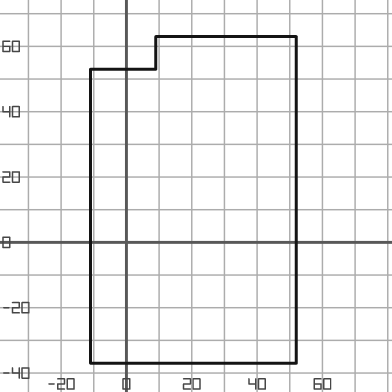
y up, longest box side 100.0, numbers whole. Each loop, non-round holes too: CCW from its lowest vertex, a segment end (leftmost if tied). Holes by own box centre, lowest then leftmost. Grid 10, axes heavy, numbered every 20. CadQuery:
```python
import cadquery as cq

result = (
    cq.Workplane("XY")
    .moveTo(-11.0, -37.0)
    .lineTo(52.0, -37.0)
    .lineTo(52.0, 63.0)
    .lineTo(9.0, 63.0)
    .lineTo(9.0, 53.0)
    .lineTo(-11.0, 53.0)
    .close()
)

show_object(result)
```